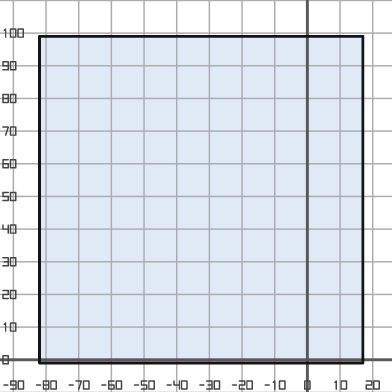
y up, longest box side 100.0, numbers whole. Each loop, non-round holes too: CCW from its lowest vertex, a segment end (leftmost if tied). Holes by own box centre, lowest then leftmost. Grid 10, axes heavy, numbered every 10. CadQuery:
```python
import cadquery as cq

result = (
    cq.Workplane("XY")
    .moveTo(-82.0, -1.0)
    .lineTo(17.0, -1.0)
    .lineTo(17.0, 99.0)
    .lineTo(-82.0, 99.0)
    .close()
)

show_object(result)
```